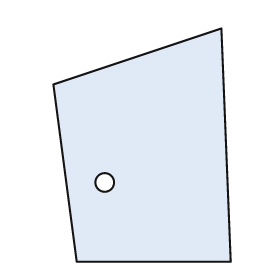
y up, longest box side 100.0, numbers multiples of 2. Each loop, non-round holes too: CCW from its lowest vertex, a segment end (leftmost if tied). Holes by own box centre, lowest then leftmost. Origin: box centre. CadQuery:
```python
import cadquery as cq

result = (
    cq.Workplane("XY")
    .moveTo(-28.0, -50.0)
    .lineTo(38.0, -50.0)
    .lineTo(34.0, 50.0)
    .lineTo(-38.0, 26.0)
    .close()
    .moveTo(-16.0, -16.0)
    .circle(4.0)
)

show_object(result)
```